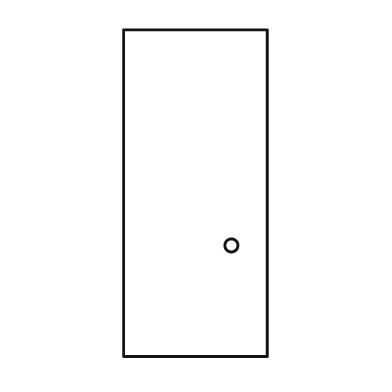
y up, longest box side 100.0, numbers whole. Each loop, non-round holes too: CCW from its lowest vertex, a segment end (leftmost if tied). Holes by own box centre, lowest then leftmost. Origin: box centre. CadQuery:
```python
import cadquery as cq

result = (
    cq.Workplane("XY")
    .moveTo(-22.0, -50.0)
    .lineTo(22.0, -50.0)
    .lineTo(22.0, 50.0)
    .lineTo(-22.0, 50.0)
    .close()
    .moveTo(11.0, -16.0)
    .circle(2.0)
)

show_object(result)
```